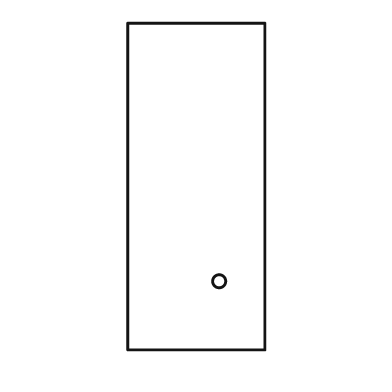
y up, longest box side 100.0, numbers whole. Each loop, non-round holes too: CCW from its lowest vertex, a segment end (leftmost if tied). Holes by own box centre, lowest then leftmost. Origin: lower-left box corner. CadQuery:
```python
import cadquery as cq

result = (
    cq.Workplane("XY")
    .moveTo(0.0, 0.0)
    .lineTo(42.0, 0.0)
    .lineTo(42.0, 100.0)
    .lineTo(0.0, 100.0)
    .close()
    .moveTo(28.0, 21.0)
    .circle(2.0)
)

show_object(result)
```